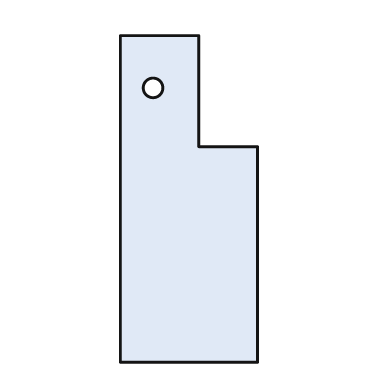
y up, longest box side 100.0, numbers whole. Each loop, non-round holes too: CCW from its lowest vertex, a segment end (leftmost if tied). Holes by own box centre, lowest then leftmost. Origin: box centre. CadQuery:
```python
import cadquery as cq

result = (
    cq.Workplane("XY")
    .moveTo(-21.0, -50.0)
    .lineTo(21.0, -50.0)
    .lineTo(21.0, 16.0)
    .lineTo(3.0, 16.0)
    .lineTo(3.0, 50.0)
    .lineTo(-21.0, 50.0)
    .close()
    .moveTo(-11.0, 34.0)
    .circle(3.0)
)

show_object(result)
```